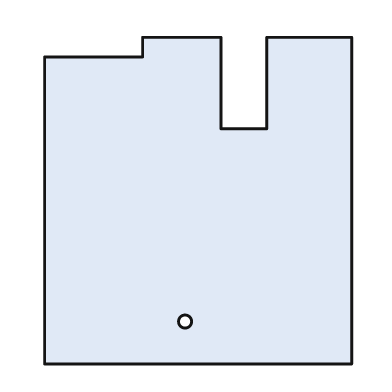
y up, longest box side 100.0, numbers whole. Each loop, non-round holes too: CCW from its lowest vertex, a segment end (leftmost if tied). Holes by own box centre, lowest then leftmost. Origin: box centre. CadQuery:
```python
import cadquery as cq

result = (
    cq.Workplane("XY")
    .moveTo(-47.0, -50.0)
    .lineTo(47.0, -50.0)
    .lineTo(47.0, 50.0)
    .lineTo(21.0, 50.0)
    .lineTo(21.0, 22.0)
    .lineTo(7.0, 22.0)
    .lineTo(7.0, 50.0)
    .lineTo(-17.0, 50.0)
    .lineTo(-17.0, 44.0)
    .lineTo(-47.0, 44.0)
    .close()
    .moveTo(-4.0, -37.0)
    .circle(2.0)
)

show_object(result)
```